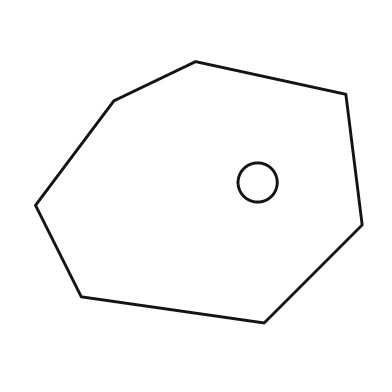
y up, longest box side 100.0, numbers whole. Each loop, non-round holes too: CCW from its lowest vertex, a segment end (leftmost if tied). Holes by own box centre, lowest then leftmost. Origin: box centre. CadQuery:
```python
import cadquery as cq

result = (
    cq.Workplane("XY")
    .moveTo(20.0, -40.0)
    .lineTo(50.0, -10.0)
    .lineTo(45.0, 30.0)
    .lineTo(-1.0, 40.0)
    .lineTo(-26.0, 28.0)
    .lineTo(-50.0, -4.0)
    .lineTo(-36.0, -32.0)
    .close()
    .moveTo(18.0, 3.0)
    .circle(6.0)
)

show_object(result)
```